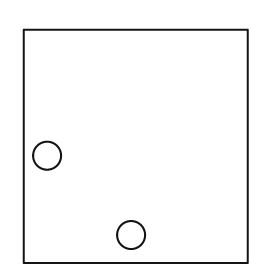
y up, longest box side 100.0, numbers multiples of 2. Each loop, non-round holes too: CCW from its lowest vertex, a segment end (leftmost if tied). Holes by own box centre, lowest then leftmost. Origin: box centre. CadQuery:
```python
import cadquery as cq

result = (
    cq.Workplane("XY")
    .moveTo(-48.0, -50.0)
    .lineTo(48.0, -50.0)
    .lineTo(48.0, 50.0)
    .lineTo(-48.0, 50.0)
    .close()
    .moveTo(-2.0, -38.0)
    .circle(6.0)
    .moveTo(-38.0, -4.0)
    .circle(6.0)
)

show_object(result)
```